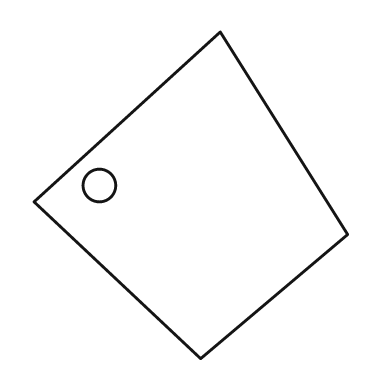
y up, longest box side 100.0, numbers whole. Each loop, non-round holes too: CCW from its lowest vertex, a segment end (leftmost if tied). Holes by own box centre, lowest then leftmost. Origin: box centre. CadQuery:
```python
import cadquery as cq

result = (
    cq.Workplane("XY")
    .moveTo(3.0, -50.0)
    .lineTo(48.0, -12.0)
    .lineTo(9.0, 50.0)
    .lineTo(-48.0, -2.0)
    .close()
    .moveTo(-28.0, 3.0)
    .circle(5.0)
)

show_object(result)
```